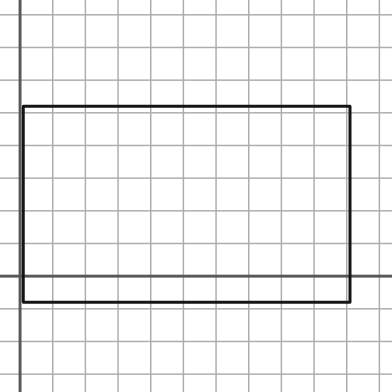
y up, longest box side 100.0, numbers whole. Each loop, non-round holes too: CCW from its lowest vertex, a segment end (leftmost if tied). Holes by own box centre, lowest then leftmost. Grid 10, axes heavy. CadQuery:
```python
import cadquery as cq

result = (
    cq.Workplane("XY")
    .moveTo(1.0, -8.0)
    .lineTo(101.0, -8.0)
    .lineTo(101.0, 52.0)
    .lineTo(1.0, 52.0)
    .close()
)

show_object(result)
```